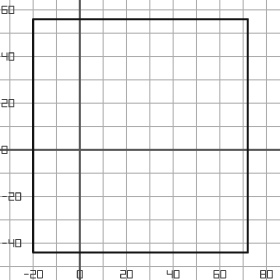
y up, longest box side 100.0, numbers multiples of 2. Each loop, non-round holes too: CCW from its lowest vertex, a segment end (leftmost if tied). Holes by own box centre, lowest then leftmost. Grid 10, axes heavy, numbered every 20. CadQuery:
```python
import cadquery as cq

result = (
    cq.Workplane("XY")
    .moveTo(-20.0, -44.0)
    .lineTo(72.0, -44.0)
    .lineTo(72.0, 56.0)
    .lineTo(-20.0, 56.0)
    .close()
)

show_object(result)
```